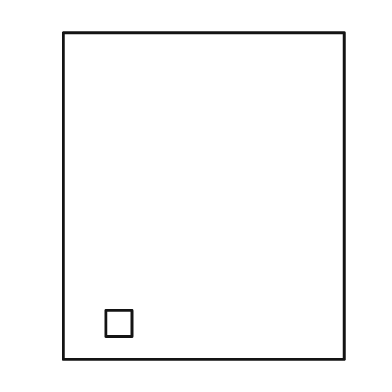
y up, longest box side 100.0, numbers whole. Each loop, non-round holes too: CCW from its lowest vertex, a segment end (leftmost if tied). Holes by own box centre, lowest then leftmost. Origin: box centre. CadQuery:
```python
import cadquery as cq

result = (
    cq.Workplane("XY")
    .moveTo(-43.0, -50.0)
    .lineTo(43.0, -50.0)
    .lineTo(43.0, 50.0)
    .lineTo(-43.0, 50.0)
    .close()
    .moveTo(-30.0, -43.0)
    .lineTo(-22.0, -43.0)
    .lineTo(-22.0, -35.0)
    .lineTo(-30.0, -35.0)
    .close()
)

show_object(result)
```